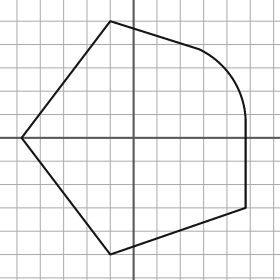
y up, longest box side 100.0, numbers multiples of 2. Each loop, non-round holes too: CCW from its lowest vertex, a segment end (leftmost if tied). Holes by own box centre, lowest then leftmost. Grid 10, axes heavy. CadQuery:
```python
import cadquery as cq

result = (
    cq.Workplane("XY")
    .moveTo(-10.0, -50.0)
    .lineTo(48.0, -30.0)
    .lineTo(48.0, 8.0)
    .threePointArc((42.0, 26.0), (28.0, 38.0))
    .lineTo(-10.0, 50.0)
    .lineTo(-48.0, 0.0)
    .close()
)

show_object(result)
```